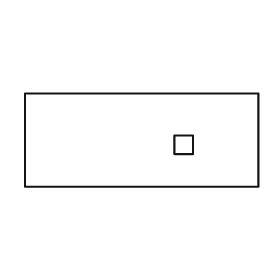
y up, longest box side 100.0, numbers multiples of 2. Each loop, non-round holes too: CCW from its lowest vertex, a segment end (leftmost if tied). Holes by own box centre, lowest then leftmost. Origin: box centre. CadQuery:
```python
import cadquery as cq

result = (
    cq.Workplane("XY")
    .moveTo(-50.0, -20.0)
    .lineTo(50.0, -20.0)
    .lineTo(50.0, 20.0)
    .lineTo(-50.0, 20.0)
    .close()
    .moveTo(14.0, -6.0)
    .lineTo(22.0, -6.0)
    .lineTo(22.0, 2.0)
    .lineTo(14.0, 2.0)
    .close()
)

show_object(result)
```